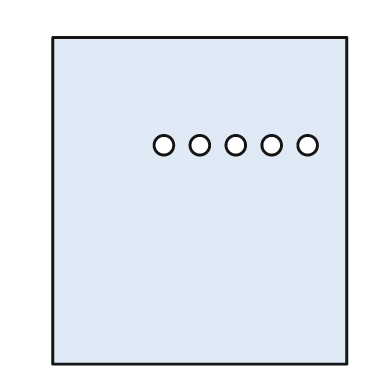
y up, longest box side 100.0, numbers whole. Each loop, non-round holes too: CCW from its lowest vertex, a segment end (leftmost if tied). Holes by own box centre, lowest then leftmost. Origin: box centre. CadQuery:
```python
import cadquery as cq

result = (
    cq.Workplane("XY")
    .moveTo(-45.0, -50.0)
    .lineTo(45.0, -50.0)
    .lineTo(45.0, 50.0)
    .lineTo(-45.0, 50.0)
    .close()
    .moveTo(-11.0, 17.0)
    .circle(3.0)
    .moveTo(0.0, 17.0)
    .circle(3.0)
    .moveTo(11.0, 17.0)
    .circle(3.0)
    .moveTo(22.0, 17.0)
    .circle(3.0)
    .moveTo(33.0, 17.0)
    .circle(3.0)
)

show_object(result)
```